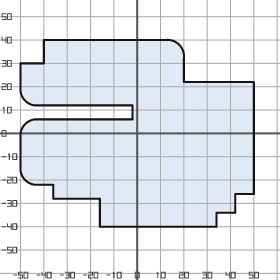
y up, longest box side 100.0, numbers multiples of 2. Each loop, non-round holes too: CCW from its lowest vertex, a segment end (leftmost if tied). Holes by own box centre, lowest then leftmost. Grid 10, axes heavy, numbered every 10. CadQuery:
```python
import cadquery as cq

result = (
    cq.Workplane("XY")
    .moveTo(-16.0, -40.0)
    .lineTo(34.0, -40.0)
    .lineTo(34.0, -34.0)
    .lineTo(42.0, -34.0)
    .lineTo(42.0, -26.0)
    .lineTo(50.0, -26.0)
    .lineTo(50.0, 22.0)
    .lineTo(20.0, 22.0)
    .lineTo(20.0, 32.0)
    .threePointArc((18.0, 38.0), (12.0, 40.0))
    .lineTo(-40.0, 40.0)
    .lineTo(-40.0, 30.0)
    .lineTo(-50.0, 30.0)
    .lineTo(-50.0, 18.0)
    .threePointArc((-48.0, 14.0), (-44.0, 12.0))
    .lineTo(-2.0, 12.0)
    .lineTo(-2.0, 6.0)
    .lineTo(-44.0, 6.0)
    .threePointArc((-48.0, 4.0), (-50.0, 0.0))
    .lineTo(-50.0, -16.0)
    .threePointArc((-48.0, -20.0), (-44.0, -22.0))
    .lineTo(-36.0, -22.0)
    .lineTo(-36.0, -28.0)
    .lineTo(-16.0, -28.0)
    .close()
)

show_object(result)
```